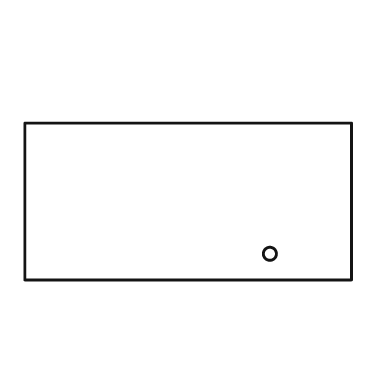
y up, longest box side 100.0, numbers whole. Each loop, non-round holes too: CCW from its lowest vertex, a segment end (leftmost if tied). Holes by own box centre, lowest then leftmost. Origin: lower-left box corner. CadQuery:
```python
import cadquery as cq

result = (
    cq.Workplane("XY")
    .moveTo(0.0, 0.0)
    .lineTo(100.0, 0.0)
    .lineTo(100.0, 48.0)
    .lineTo(0.0, 48.0)
    .close()
    .moveTo(75.0, 8.0)
    .circle(2.0)
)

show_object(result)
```